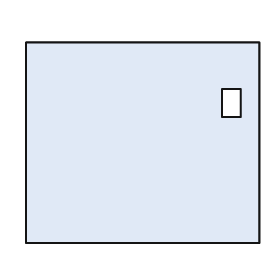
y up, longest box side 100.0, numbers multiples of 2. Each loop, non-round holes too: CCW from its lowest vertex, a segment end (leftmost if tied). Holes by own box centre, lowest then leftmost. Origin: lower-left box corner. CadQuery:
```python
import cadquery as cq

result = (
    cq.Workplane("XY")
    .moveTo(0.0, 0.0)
    .lineTo(100.0, 0.0)
    .lineTo(100.0, 86.0)
    .lineTo(0.0, 86.0)
    .close()
    .moveTo(84.0, 54.0)
    .lineTo(92.0, 54.0)
    .lineTo(92.0, 66.0)
    .lineTo(84.0, 66.0)
    .close()
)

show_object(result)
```